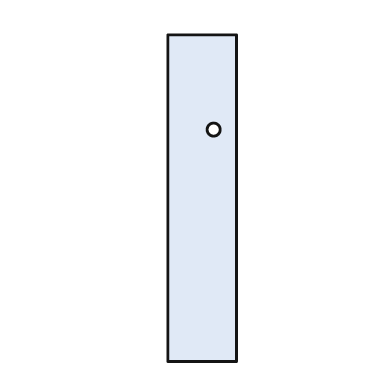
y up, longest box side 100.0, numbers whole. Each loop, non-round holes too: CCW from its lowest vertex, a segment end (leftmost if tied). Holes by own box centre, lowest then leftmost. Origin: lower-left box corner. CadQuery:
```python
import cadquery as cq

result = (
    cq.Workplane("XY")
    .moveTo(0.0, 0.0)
    .lineTo(21.0, 0.0)
    .lineTo(21.0, 100.0)
    .lineTo(0.0, 100.0)
    .close()
    .moveTo(14.0, 71.0)
    .circle(2.0)
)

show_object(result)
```